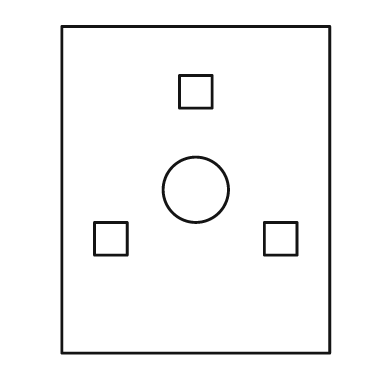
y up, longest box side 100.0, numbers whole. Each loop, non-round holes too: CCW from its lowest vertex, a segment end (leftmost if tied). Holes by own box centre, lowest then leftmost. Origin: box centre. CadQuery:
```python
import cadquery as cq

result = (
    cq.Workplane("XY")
    .moveTo(-41.0, -50.0)
    .lineTo(41.0, -50.0)
    .lineTo(41.0, 50.0)
    .lineTo(-41.0, 50.0)
    .close()
    .moveTo(-31.0, -20.0)
    .lineTo(-21.0, -20.0)
    .lineTo(-21.0, -10.0)
    .lineTo(-31.0, -10.0)
    .close()
    .moveTo(21.0, -20.0)
    .lineTo(31.0, -20.0)
    .lineTo(31.0, -10.0)
    .lineTo(21.0, -10.0)
    .close()
    .moveTo(0.0, 0.0)
    .circle(10.0)
    .moveTo(-5.0, 25.0)
    .lineTo(5.0, 25.0)
    .lineTo(5.0, 35.0)
    .lineTo(-5.0, 35.0)
    .close()
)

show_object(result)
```